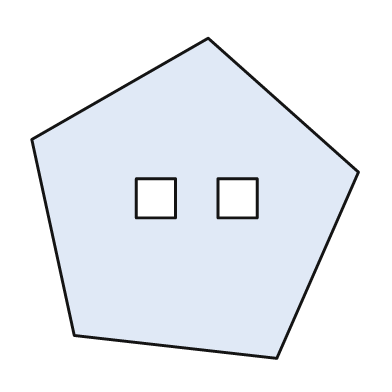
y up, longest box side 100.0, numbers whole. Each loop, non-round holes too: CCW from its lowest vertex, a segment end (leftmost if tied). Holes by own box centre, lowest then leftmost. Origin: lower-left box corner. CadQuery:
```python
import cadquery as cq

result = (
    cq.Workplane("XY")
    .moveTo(75.0, 0.0)
    .lineTo(100.0, 57.0)
    .lineTo(54.0, 98.0)
    .lineTo(0.0, 67.0)
    .lineTo(13.0, 7.0)
    .close()
    .moveTo(32.0, 43.0)
    .lineTo(44.0, 43.0)
    .lineTo(44.0, 55.0)
    .lineTo(32.0, 55.0)
    .close()
    .moveTo(57.0, 43.0)
    .lineTo(69.0, 43.0)
    .lineTo(69.0, 55.0)
    .lineTo(57.0, 55.0)
    .close()
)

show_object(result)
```